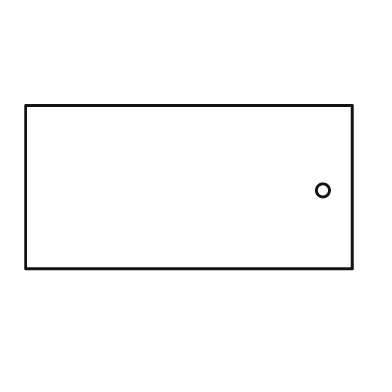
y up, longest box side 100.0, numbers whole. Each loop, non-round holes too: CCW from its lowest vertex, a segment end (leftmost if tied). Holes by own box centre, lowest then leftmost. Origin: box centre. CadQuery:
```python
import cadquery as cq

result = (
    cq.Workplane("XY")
    .moveTo(-50.0, -25.0)
    .lineTo(50.0, -25.0)
    .lineTo(50.0, 25.0)
    .lineTo(-50.0, 25.0)
    .close()
    .moveTo(41.0, -1.0)
    .circle(2.0)
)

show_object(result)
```